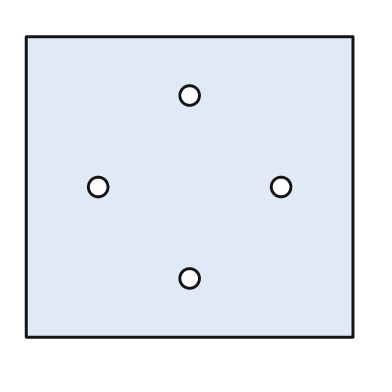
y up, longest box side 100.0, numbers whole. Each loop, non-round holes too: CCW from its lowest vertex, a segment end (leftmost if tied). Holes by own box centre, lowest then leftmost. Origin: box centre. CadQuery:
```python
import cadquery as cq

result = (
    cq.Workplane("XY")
    .moveTo(-50.0, -46.0)
    .lineTo(50.0, -46.0)
    .lineTo(50.0, 46.0)
    .lineTo(-50.0, 46.0)
    .close()
    .moveTo(0.0, -28.0)
    .circle(3.0)
    .moveTo(-28.0, 0.0)
    .circle(3.0)
    .moveTo(28.0, 0.0)
    .circle(3.0)
    .moveTo(0.0, 28.0)
    .circle(3.0)
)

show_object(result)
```